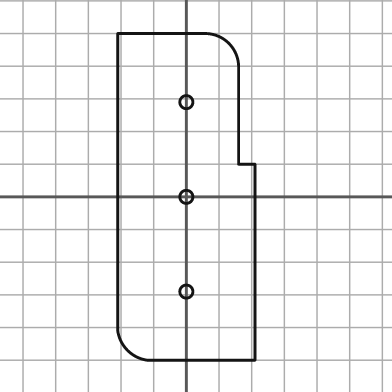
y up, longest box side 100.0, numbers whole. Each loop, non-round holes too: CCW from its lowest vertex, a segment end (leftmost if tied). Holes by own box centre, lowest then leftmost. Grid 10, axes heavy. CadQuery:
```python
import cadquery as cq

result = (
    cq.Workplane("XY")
    .moveTo(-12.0, -50.0)
    .lineTo(21.0, -50.0)
    .lineTo(21.0, 10.0)
    .lineTo(16.0, 10.0)
    .lineTo(16.0, 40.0)
    .threePointArc((13.0, 47.0), (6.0, 50.0))
    .lineTo(-21.0, 50.0)
    .lineTo(-21.0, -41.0)
    .threePointArc((-18.0, -47.0), (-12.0, -50.0))
    .close()
    .moveTo(0.0, -29.0)
    .circle(2.0)
    .moveTo(0.0, 0.0)
    .circle(2.0)
    .moveTo(0.0, 29.0)
    .circle(2.0)
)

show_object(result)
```